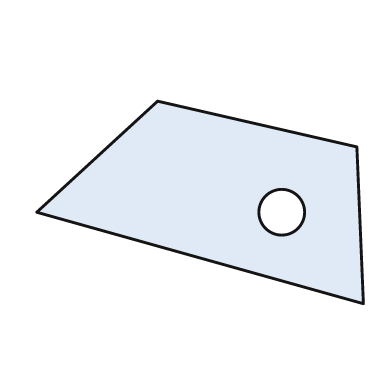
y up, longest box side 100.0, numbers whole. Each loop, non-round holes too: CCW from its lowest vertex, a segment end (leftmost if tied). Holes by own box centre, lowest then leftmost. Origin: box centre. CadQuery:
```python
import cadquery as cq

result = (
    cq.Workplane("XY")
    .moveTo(50.0, -31.0)
    .lineTo(48.0, 17.0)
    .lineTo(-13.0, 31.0)
    .lineTo(-50.0, -3.0)
    .close()
    .moveTo(25.0, -3.0)
    .circle(7.0)
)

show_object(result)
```